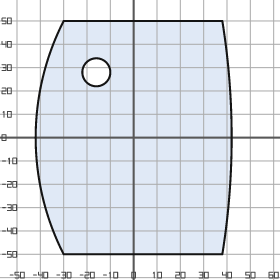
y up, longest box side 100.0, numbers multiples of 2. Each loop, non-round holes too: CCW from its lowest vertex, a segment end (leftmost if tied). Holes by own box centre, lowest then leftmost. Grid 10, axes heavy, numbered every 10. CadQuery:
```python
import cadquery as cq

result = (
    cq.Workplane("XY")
    .moveTo(-30.0, -50.0)
    .lineTo(38.0, -50.0)
    .threePointArc((42.0, 0.0), (38.0, 50.0))
    .lineTo(-30.0, 50.0)
    .threePointArc((-42.0, 0.0), (-30.0, -50.0))
    .close()
    .moveTo(-16.0, 28.0)
    .circle(6.0)
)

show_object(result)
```